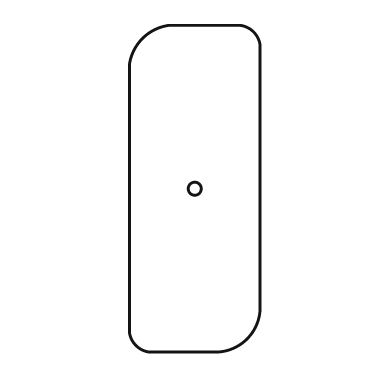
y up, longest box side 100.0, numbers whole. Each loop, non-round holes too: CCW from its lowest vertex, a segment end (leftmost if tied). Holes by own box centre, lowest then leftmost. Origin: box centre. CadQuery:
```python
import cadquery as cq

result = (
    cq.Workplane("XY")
    .moveTo(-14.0, -50.0)
    .lineTo(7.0, -50.0)
    .threePointArc((16.0, -46.0), (20.0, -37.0))
    .lineTo(20.0, 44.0)
    .threePointArc((18.0, 48.0), (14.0, 50.0))
    .lineTo(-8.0, 50.0)
    .threePointArc((-16.0, 46.0), (-20.0, 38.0))
    .lineTo(-20.0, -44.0)
    .threePointArc((-18.0, -48.0), (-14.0, -50.0))
    .close()
    .moveTo(0.0, 0.0)
    .circle(2.0)
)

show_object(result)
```